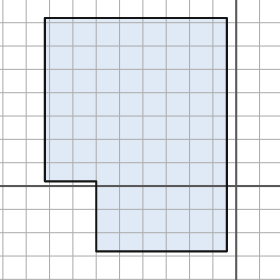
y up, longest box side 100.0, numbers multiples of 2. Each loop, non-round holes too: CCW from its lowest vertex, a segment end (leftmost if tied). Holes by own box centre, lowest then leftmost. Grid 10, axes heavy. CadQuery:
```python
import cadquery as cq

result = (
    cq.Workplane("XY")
    .moveTo(-60.0, -28.0)
    .lineTo(-4.0, -28.0)
    .lineTo(-4.0, 72.0)
    .lineTo(-82.0, 72.0)
    .lineTo(-82.0, 2.0)
    .lineTo(-60.0, 2.0)
    .close()
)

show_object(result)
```